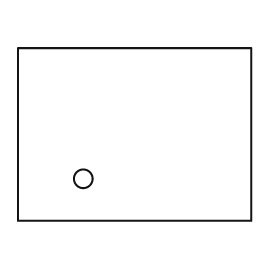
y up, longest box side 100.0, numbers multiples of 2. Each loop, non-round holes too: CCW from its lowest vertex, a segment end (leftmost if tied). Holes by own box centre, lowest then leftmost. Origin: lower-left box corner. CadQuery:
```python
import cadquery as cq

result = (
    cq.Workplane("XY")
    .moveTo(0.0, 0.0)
    .lineTo(100.0, 0.0)
    .lineTo(100.0, 74.0)
    .lineTo(0.0, 74.0)
    .close()
    .moveTo(28.0, 18.0)
    .circle(4.0)
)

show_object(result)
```